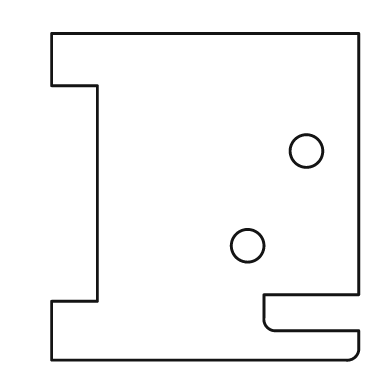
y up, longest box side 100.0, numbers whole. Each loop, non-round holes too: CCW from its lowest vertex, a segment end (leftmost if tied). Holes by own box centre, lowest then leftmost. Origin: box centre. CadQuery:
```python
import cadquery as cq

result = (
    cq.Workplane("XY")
    .moveTo(-47.0, -50.0)
    .lineTo(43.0, -50.0)
    .threePointArc((46.0, -49.0), (47.0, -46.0))
    .lineTo(47.0, -41.0)
    .lineTo(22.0, -41.0)
    .threePointArc((19.0, -40.0), (18.0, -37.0))
    .lineTo(18.0, -30.0)
    .lineTo(47.0, -30.0)
    .lineTo(47.0, 50.0)
    .lineTo(-47.0, 50.0)
    .lineTo(-47.0, 34.0)
    .lineTo(-33.0, 34.0)
    .lineTo(-33.0, -32.0)
    .lineTo(-47.0, -32.0)
    .close()
    .moveTo(13.0, -15.0)
    .circle(5.0)
    .moveTo(31.0, 14.0)
    .circle(5.0)
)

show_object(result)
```